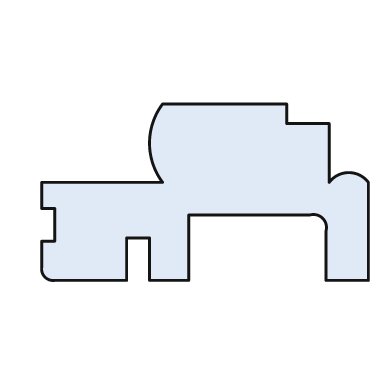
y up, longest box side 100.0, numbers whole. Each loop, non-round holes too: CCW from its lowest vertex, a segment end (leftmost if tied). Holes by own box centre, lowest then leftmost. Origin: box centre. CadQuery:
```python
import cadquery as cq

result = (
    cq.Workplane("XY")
    .moveTo(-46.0, -27.0)
    .lineTo(-24.0, -27.0)
    .lineTo(-24.0, -14.0)
    .lineTo(-17.0, -14.0)
    .lineTo(-17.0, -27.0)
    .lineTo(-5.0, -27.0)
    .lineTo(-5.0, -7.0)
    .lineTo(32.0, -7.0)
    .threePointArc((36.0, -8.0), (37.0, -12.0))
    .lineTo(37.0, -27.0)
    .lineTo(50.0, -27.0)
    .lineTo(50.0, 3.0)
    .threePointArc((44.0, 6.0), (38.0, 3.0))
    .lineTo(38.0, 21.0)
    .lineTo(25.0, 21.0)
    .lineTo(25.0, 27.0)
    .lineTo(-13.0, 27.0)
    .threePointArc((-17.0, 15.0), (-13.0, 3.0))
    .lineTo(-50.0, 3.0)
    .lineTo(-50.0, -5.0)
    .lineTo(-46.0, -5.0)
    .lineTo(-46.0, -15.0)
    .lineTo(-50.0, -15.0)
    .lineTo(-50.0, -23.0)
    .threePointArc((-49.0, -26.0), (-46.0, -27.0))
    .close()
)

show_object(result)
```